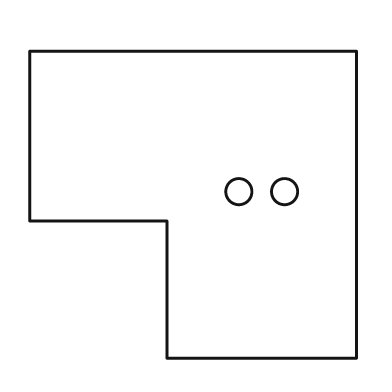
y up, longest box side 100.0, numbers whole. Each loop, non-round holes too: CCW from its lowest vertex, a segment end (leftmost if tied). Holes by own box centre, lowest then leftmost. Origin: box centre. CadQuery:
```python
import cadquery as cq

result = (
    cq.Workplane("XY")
    .moveTo(-8.0, -47.0)
    .lineTo(50.0, -47.0)
    .lineTo(50.0, 47.0)
    .lineTo(-50.0, 47.0)
    .lineTo(-50.0, -5.0)
    .lineTo(-8.0, -5.0)
    .close()
    .moveTo(14.0, 4.0)
    .circle(4.0)
    .moveTo(28.0, 4.0)
    .circle(4.0)
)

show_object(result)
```